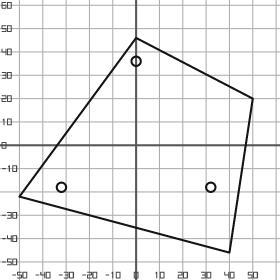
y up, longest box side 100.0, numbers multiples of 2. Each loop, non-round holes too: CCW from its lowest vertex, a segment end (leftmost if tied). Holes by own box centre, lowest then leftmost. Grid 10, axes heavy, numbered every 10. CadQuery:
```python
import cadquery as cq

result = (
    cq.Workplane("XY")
    .moveTo(40.0, -46.0)
    .lineTo(50.0, 20.0)
    .lineTo(0.0, 46.0)
    .lineTo(-50.0, -22.0)
    .close()
    .moveTo(-32.0, -18.0)
    .circle(2.0)
    .moveTo(32.0, -18.0)
    .circle(2.0)
    .moveTo(0.0, 36.0)
    .circle(2.0)
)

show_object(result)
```